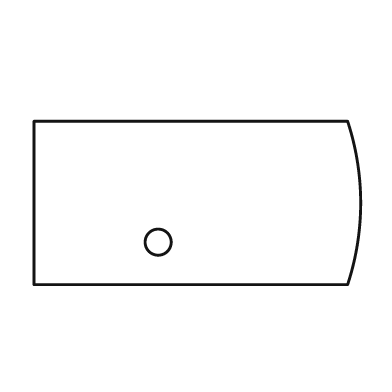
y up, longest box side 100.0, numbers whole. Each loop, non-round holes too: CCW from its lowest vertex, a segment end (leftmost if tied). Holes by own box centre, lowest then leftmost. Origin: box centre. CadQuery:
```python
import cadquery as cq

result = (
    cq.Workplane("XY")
    .moveTo(-50.0, -25.0)
    .lineTo(46.0, -25.0)
    .threePointArc((50.0, 0.0), (46.0, 25.0))
    .lineTo(-50.0, 25.0)
    .close()
    .moveTo(-12.0, -12.0)
    .circle(4.0)
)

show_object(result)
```